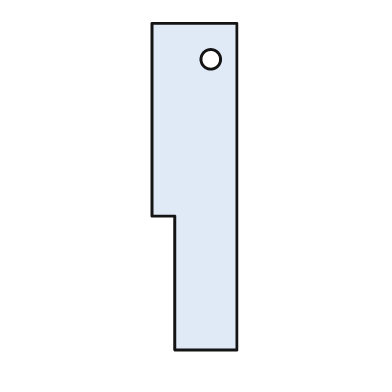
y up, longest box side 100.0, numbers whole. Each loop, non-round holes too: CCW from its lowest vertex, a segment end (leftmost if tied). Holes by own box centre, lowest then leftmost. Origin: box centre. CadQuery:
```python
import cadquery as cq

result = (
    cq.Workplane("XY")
    .moveTo(-6.0, -50.0)
    .lineTo(13.0, -50.0)
    .lineTo(13.0, 50.0)
    .lineTo(-13.0, 50.0)
    .lineTo(-13.0, -9.0)
    .lineTo(-6.0, -9.0)
    .close()
    .moveTo(5.0, 39.0)
    .circle(3.0)
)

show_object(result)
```